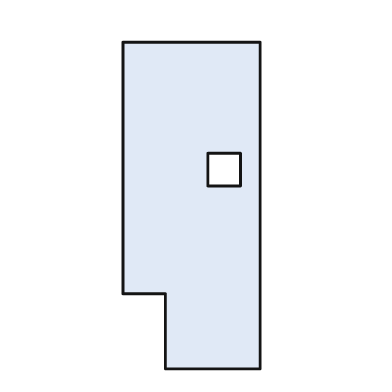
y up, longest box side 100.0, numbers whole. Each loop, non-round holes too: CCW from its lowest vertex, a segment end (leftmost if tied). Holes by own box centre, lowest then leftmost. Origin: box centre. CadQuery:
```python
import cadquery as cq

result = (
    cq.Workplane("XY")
    .moveTo(-8.0, -50.0)
    .lineTo(21.0, -50.0)
    .lineTo(21.0, 50.0)
    .lineTo(-21.0, 50.0)
    .lineTo(-21.0, -27.0)
    .lineTo(-8.0, -27.0)
    .close()
    .moveTo(5.0, 6.0)
    .lineTo(15.0, 6.0)
    .lineTo(15.0, 16.0)
    .lineTo(5.0, 16.0)
    .close()
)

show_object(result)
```